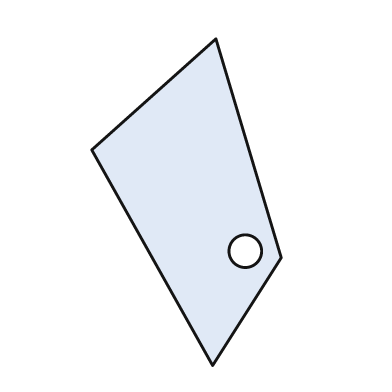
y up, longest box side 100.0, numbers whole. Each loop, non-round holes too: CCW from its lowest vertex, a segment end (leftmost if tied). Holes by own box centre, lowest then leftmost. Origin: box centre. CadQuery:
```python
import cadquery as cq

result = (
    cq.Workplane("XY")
    .moveTo(8.0, -50.0)
    .lineTo(29.0, -17.0)
    .lineTo(9.0, 50.0)
    .lineTo(-29.0, 16.0)
    .close()
    .moveTo(18.0, -15.0)
    .circle(5.0)
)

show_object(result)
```